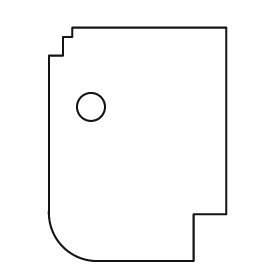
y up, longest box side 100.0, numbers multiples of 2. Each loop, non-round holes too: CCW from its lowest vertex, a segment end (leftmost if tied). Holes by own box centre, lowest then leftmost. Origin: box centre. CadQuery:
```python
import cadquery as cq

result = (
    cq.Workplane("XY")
    .moveTo(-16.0, -50.0)
    .lineTo(24.0, -50.0)
    .lineTo(24.0, -30.0)
    .lineTo(38.0, -30.0)
    .lineTo(38.0, 50.0)
    .lineTo(-28.0, 50.0)
    .lineTo(-28.0, 46.0)
    .lineTo(-32.0, 46.0)
    .lineTo(-32.0, 38.0)
    .lineTo(-38.0, 38.0)
    .lineTo(-38.0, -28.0)
    .threePointArc((-32.0, -44.0), (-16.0, -50.0))
    .close()
    .moveTo(-20.0, 16.0)
    .circle(6.0)
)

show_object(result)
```